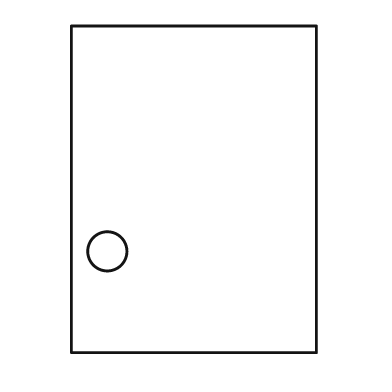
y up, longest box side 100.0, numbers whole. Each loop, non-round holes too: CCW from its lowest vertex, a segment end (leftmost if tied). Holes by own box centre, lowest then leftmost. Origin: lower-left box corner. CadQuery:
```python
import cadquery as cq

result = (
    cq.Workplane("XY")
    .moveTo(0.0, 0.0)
    .lineTo(75.0, 0.0)
    .lineTo(75.0, 100.0)
    .lineTo(0.0, 100.0)
    .close()
    .moveTo(11.0, 31.0)
    .circle(6.0)
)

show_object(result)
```